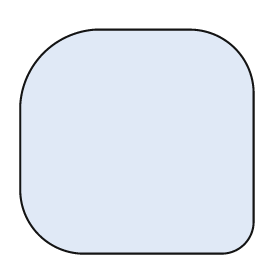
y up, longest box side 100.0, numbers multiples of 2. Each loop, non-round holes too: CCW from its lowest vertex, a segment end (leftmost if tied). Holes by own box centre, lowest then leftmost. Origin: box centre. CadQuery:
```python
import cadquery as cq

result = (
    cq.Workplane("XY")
    .moveTo(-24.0, -48.0)
    .lineTo(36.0, -48.0)
    .threePointArc((46.0, -44.0), (50.0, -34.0))
    .lineTo(50.0, 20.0)
    .threePointArc((42.0, 40.0), (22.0, 48.0))
    .lineTo(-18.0, 48.0)
    .threePointArc((-40.0, 38.0), (-50.0, 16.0))
    .lineTo(-50.0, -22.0)
    .threePointArc((-42.0, -40.0), (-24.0, -48.0))
    .close()
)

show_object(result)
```